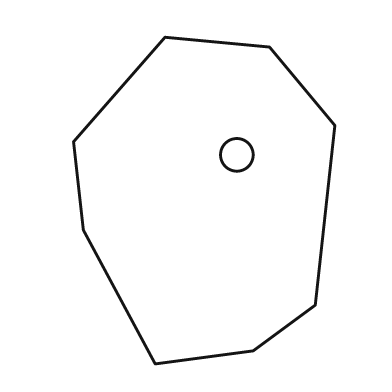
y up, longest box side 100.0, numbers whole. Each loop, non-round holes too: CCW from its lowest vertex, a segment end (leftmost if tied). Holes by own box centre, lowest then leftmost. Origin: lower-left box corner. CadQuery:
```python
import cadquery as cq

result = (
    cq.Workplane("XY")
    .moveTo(25.0, 0.0)
    .lineTo(55.0, 4.0)
    .lineTo(74.0, 18.0)
    .lineTo(80.0, 73.0)
    .lineTo(60.0, 97.0)
    .lineTo(28.0, 100.0)
    .lineTo(0.0, 68.0)
    .lineTo(3.0, 41.0)
    .close()
    .moveTo(50.0, 64.0)
    .circle(5.0)
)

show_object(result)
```